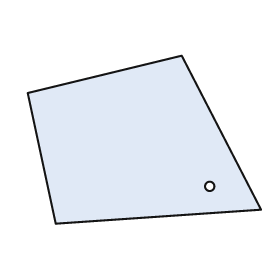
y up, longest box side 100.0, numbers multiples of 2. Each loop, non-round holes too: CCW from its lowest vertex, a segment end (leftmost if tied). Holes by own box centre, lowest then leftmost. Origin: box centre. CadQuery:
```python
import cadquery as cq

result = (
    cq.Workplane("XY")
    .moveTo(-38.0, -36.0)
    .lineTo(50.0, -30.0)
    .lineTo(16.0, 36.0)
    .lineTo(-50.0, 20.0)
    .close()
    .moveTo(28.0, -20.0)
    .circle(2.0)
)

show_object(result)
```